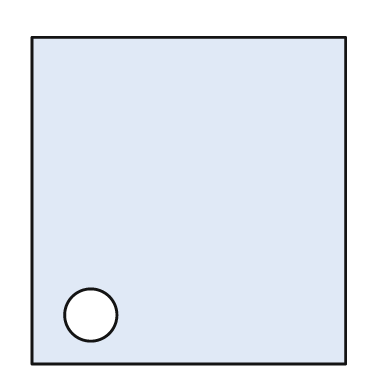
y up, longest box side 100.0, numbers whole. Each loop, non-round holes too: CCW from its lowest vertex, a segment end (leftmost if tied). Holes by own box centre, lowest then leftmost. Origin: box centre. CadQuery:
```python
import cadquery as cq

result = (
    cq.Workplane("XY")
    .moveTo(-48.0, -50.0)
    .lineTo(48.0, -50.0)
    .lineTo(48.0, 50.0)
    .lineTo(-48.0, 50.0)
    .close()
    .moveTo(-30.0, -35.0)
    .circle(8.0)
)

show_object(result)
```